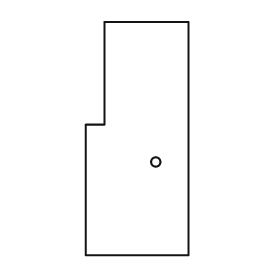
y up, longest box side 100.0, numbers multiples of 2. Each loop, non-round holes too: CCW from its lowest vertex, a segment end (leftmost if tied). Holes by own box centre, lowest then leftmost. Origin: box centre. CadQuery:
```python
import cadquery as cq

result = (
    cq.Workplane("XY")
    .moveTo(-22.0, -50.0)
    .lineTo(22.0, -50.0)
    .lineTo(22.0, 50.0)
    .lineTo(-14.0, 50.0)
    .lineTo(-14.0, 6.0)
    .lineTo(-22.0, 6.0)
    .close()
    .moveTo(8.0, -10.0)
    .circle(2.0)
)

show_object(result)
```